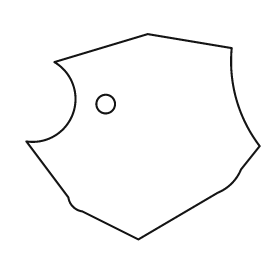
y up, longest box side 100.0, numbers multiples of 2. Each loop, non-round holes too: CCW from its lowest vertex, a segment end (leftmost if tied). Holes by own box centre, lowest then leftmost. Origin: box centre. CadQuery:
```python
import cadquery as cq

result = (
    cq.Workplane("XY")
    .moveTo(-2.0, -44.0)
    .lineTo(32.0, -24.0)
    .threePointArc((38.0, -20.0), (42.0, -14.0))
    .lineTo(50.0, -4.0)
    .threePointArc((40.0, 16.0), (38.0, 38.0))
    .lineTo(2.0, 44.0)
    .lineTo(-38.0, 32.0)
    .threePointArc((-30.0, 10.0), (-50.0, -2.0))
    .lineTo(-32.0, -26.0)
    .threePointArc((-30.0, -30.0), (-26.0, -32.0))
    .close()
    .moveTo(-16.0, 14.0)
    .circle(4.0)
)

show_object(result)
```